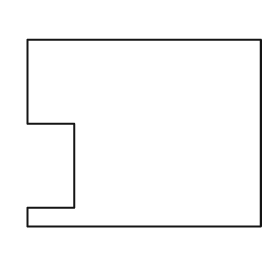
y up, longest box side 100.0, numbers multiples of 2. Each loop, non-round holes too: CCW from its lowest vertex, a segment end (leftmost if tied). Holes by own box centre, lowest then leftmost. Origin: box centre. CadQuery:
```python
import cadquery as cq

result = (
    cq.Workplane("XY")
    .moveTo(-50.0, -40.0)
    .lineTo(50.0, -40.0)
    .lineTo(50.0, 40.0)
    .lineTo(-50.0, 40.0)
    .lineTo(-50.0, 4.0)
    .lineTo(-30.0, 4.0)
    .lineTo(-30.0, -32.0)
    .lineTo(-50.0, -32.0)
    .close()
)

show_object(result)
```